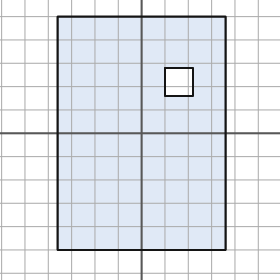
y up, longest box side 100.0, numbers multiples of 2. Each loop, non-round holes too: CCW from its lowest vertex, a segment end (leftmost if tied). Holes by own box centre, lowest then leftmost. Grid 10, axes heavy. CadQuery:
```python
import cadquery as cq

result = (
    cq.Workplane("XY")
    .moveTo(-36.0, -50.0)
    .lineTo(36.0, -50.0)
    .lineTo(36.0, 50.0)
    .lineTo(-36.0, 50.0)
    .close()
    .moveTo(10.0, 16.0)
    .lineTo(22.0, 16.0)
    .lineTo(22.0, 28.0)
    .lineTo(10.0, 28.0)
    .close()
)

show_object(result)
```